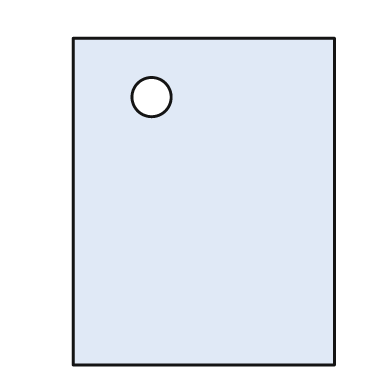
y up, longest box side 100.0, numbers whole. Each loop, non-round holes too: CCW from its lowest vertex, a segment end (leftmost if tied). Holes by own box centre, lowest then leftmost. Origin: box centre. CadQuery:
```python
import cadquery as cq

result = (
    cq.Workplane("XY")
    .moveTo(-40.0, -50.0)
    .lineTo(40.0, -50.0)
    .lineTo(40.0, 50.0)
    .lineTo(-40.0, 50.0)
    .close()
    .moveTo(-16.0, 32.0)
    .circle(6.0)
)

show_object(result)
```